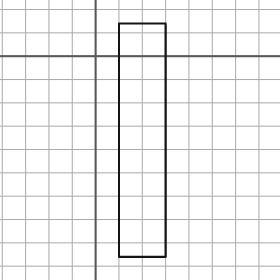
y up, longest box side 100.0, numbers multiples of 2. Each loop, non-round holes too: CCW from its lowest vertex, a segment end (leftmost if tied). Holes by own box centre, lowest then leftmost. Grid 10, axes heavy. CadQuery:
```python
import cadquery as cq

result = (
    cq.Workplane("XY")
    .moveTo(10.0, -86.0)
    .lineTo(30.0, -86.0)
    .lineTo(30.0, 14.0)
    .lineTo(10.0, 14.0)
    .close()
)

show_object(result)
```